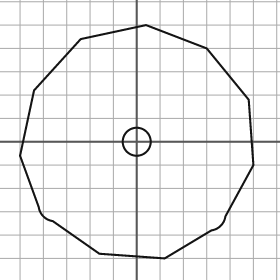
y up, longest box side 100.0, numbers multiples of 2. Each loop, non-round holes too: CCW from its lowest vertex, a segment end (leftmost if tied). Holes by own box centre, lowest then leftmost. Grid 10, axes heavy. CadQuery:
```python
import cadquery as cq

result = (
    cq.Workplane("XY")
    .moveTo(12.0, -50.0)
    .lineTo(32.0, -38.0)
    .threePointArc((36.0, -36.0), (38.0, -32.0))
    .lineTo(50.0, -10.0)
    .lineTo(48.0, 18.0)
    .lineTo(30.0, 40.0)
    .lineTo(4.0, 50.0)
    .lineTo(-24.0, 44.0)
    .lineTo(-44.0, 22.0)
    .lineTo(-50.0, -6.0)
    .lineTo(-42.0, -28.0)
    .threePointArc((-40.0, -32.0), (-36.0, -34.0))
    .lineTo(-16.0, -48.0)
    .close()
    .moveTo(0.0, 0.0)
    .circle(6.0)
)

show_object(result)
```